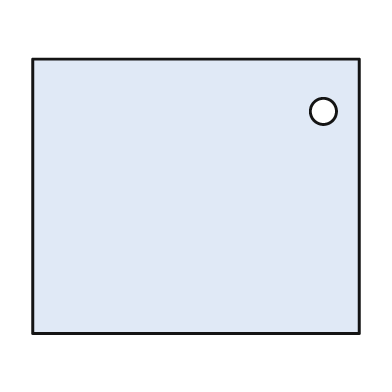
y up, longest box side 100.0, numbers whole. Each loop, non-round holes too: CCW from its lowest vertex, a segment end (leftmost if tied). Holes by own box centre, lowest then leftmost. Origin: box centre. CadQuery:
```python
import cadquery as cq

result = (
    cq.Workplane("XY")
    .moveTo(-50.0, -42.0)
    .lineTo(50.0, -42.0)
    .lineTo(50.0, 42.0)
    .lineTo(-50.0, 42.0)
    .close()
    .moveTo(39.0, 26.0)
    .circle(4.0)
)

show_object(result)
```